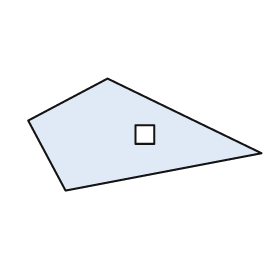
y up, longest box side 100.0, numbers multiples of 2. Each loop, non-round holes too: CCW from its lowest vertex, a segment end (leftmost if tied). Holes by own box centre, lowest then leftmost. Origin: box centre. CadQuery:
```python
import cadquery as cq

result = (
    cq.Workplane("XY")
    .moveTo(-34.0, -24.0)
    .lineTo(50.0, -8.0)
    .lineTo(-16.0, 24.0)
    .lineTo(-50.0, 6.0)
    .close()
    .moveTo(-4.0, -4.0)
    .lineTo(4.0, -4.0)
    .lineTo(4.0, 4.0)
    .lineTo(-4.0, 4.0)
    .close()
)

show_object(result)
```